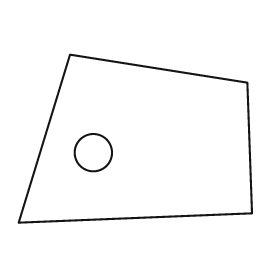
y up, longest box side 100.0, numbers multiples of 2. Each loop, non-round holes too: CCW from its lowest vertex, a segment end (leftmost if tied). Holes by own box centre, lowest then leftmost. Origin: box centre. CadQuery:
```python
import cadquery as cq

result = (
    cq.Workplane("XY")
    .moveTo(-50.0, -36.0)
    .lineTo(50.0, -32.0)
    .lineTo(48.0, 24.0)
    .lineTo(-28.0, 36.0)
    .close()
    .moveTo(-18.0, -6.0)
    .circle(8.0)
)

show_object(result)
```